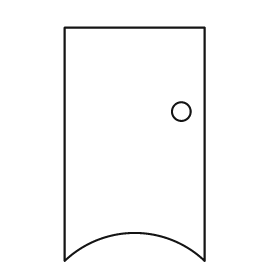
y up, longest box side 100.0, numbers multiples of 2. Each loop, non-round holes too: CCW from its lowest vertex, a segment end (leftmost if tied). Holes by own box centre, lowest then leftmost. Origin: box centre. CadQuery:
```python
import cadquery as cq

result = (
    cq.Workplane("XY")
    .moveTo(-30.0, -50.0)
    .threePointArc((0.0, -38.0), (30.0, -50.0))
    .lineTo(30.0, 50.0)
    .lineTo(-30.0, 50.0)
    .close()
    .moveTo(20.0, 14.0)
    .circle(4.0)
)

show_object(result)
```